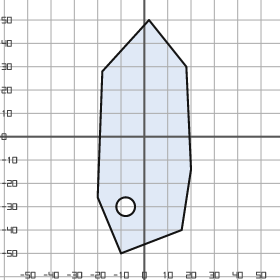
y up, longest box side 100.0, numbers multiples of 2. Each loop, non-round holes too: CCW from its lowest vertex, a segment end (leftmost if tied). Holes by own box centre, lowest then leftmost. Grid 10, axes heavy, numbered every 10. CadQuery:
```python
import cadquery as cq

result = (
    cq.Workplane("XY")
    .moveTo(-10.0, -50.0)
    .lineTo(16.0, -40.0)
    .lineTo(20.0, -14.0)
    .lineTo(18.0, 30.0)
    .lineTo(2.0, 50.0)
    .lineTo(-18.0, 28.0)
    .lineTo(-20.0, -26.0)
    .close()
    .moveTo(-8.0, -30.0)
    .circle(4.0)
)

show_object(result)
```